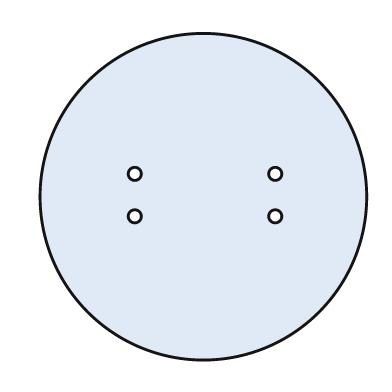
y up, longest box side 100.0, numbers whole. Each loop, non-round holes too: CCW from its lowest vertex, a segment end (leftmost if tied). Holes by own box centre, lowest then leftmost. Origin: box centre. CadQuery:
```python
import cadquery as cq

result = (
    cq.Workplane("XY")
    .moveTo(0.0, 0.0)
    .circle(50.0)
    .moveTo(-21.0, -6.0)
    .circle(2.0)
    .moveTo(22.0, -6.0)
    .circle(2.0)
    .moveTo(-21.0, 7.0)
    .circle(2.0)
    .moveTo(22.0, 7.0)
    .circle(2.0)
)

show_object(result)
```